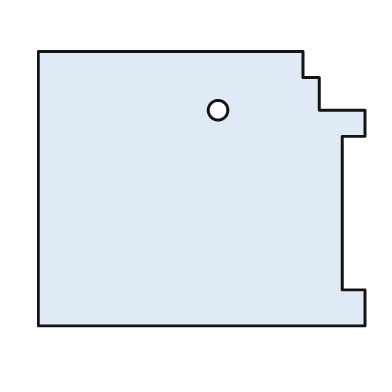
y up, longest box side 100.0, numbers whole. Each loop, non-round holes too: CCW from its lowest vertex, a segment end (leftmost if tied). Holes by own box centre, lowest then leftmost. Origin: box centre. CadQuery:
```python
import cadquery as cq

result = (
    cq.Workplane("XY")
    .moveTo(-50.0, -42.0)
    .lineTo(50.0, -42.0)
    .lineTo(50.0, -31.0)
    .lineTo(43.0, -31.0)
    .lineTo(43.0, 16.0)
    .lineTo(50.0, 16.0)
    .lineTo(50.0, 24.0)
    .lineTo(36.0, 24.0)
    .lineTo(36.0, 34.0)
    .lineTo(31.0, 34.0)
    .lineTo(31.0, 42.0)
    .lineTo(-50.0, 42.0)
    .close()
    .moveTo(5.0, 24.0)
    .circle(3.0)
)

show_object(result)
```